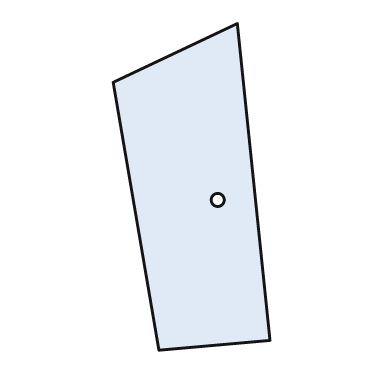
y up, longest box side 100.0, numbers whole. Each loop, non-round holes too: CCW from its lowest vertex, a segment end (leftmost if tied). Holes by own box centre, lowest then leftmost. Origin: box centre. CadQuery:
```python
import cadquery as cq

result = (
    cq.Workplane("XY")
    .moveTo(-10.0, -50.0)
    .lineTo(24.0, -47.0)
    .lineTo(14.0, 50.0)
    .lineTo(-24.0, 32.0)
    .close()
    .moveTo(8.0, -4.0)
    .circle(2.0)
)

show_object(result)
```